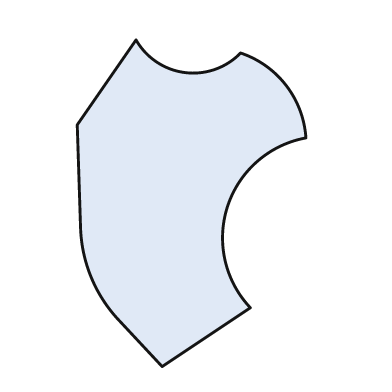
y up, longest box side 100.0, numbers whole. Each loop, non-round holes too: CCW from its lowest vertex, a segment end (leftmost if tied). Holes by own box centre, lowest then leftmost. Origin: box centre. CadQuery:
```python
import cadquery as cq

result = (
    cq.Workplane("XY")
    .moveTo(-9.0, -50.0)
    .lineTo(18.0, -32.0)
    .threePointArc((11.0, -1.0), (35.0, 20.0))
    .threePointArc((29.0, 36.0), (15.0, 46.0))
    .threePointArc((-2.0, 40.0), (-17.0, 50.0))
    .lineTo(-35.0, 24.0)
    .lineTo(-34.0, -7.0)
    .threePointArc((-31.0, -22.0), (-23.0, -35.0))
    .close()
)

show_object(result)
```